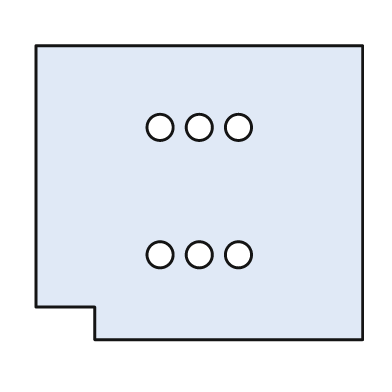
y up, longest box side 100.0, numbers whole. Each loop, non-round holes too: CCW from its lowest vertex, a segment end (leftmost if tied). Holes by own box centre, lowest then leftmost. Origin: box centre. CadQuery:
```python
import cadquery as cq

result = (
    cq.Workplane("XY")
    .moveTo(-32.0, -45.0)
    .lineTo(50.0, -45.0)
    .lineTo(50.0, 45.0)
    .lineTo(-50.0, 45.0)
    .lineTo(-50.0, -35.0)
    .lineTo(-32.0, -35.0)
    .close()
    .moveTo(-12.0, -19.0)
    .circle(4.0)
    .moveTo(0.0, -19.0)
    .circle(4.0)
    .moveTo(12.0, -19.0)
    .circle(4.0)
    .moveTo(-12.0, 20.0)
    .circle(4.0)
    .moveTo(0.0, 20.0)
    .circle(4.0)
    .moveTo(12.0, 20.0)
    .circle(4.0)
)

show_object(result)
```